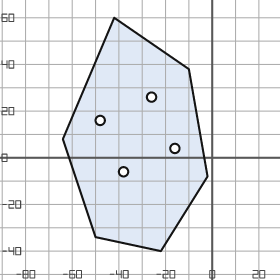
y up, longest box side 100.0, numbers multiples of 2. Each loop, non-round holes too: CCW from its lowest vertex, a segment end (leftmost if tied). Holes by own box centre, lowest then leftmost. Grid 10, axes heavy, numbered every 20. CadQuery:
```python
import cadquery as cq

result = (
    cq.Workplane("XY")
    .moveTo(-22.0, -40.0)
    .lineTo(-2.0, -8.0)
    .lineTo(-10.0, 38.0)
    .lineTo(-42.0, 60.0)
    .lineTo(-64.0, 8.0)
    .lineTo(-50.0, -34.0)
    .close()
    .moveTo(-38.0, -6.0)
    .circle(2.0)
    .moveTo(-16.0, 4.0)
    .circle(2.0)
    .moveTo(-48.0, 16.0)
    .circle(2.0)
    .moveTo(-26.0, 26.0)
    .circle(2.0)
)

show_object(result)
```